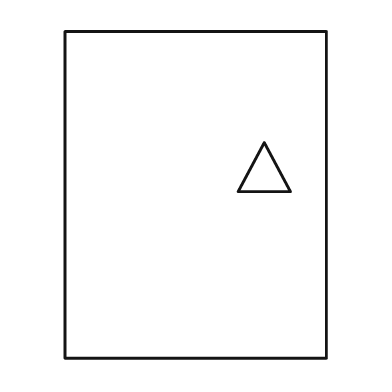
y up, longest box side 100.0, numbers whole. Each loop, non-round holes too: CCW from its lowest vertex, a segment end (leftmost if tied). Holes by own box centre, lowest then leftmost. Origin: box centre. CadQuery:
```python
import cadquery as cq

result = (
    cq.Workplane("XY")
    .moveTo(-40.0, -50.0)
    .lineTo(40.0, -50.0)
    .lineTo(40.0, 50.0)
    .lineTo(-40.0, 50.0)
    .close()
    .moveTo(13.0, 1.0)
    .lineTo(29.0, 1.0)
    .lineTo(21.0, 16.0)
    .close()
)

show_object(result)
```